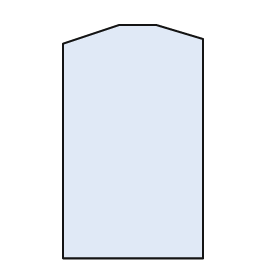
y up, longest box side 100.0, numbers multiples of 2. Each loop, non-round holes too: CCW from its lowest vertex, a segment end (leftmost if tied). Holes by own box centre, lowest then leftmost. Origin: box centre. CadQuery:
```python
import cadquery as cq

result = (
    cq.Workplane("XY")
    .moveTo(-30.0, -50.0)
    .lineTo(30.0, -50.0)
    .lineTo(30.0, 44.0)
    .lineTo(10.0, 50.0)
    .lineTo(-6.0, 50.0)
    .lineTo(-30.0, 42.0)
    .close()
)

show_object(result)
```